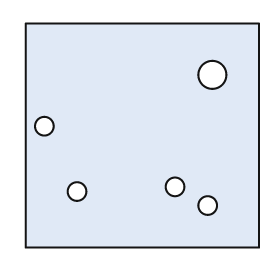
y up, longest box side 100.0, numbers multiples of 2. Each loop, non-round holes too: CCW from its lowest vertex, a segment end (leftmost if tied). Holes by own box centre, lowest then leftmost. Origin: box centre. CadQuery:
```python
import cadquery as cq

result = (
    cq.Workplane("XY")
    .moveTo(-50.0, -48.0)
    .lineTo(50.0, -48.0)
    .lineTo(50.0, 48.0)
    .lineTo(-50.0, 48.0)
    .close()
    .moveTo(28.0, -30.0)
    .circle(4.0)
    .moveTo(-28.0, -24.0)
    .circle(4.0)
    .moveTo(14.0, -22.0)
    .circle(4.0)
    .moveTo(-42.0, 4.0)
    .circle(4.0)
    .moveTo(30.0, 26.0)
    .circle(6.0)
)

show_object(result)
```